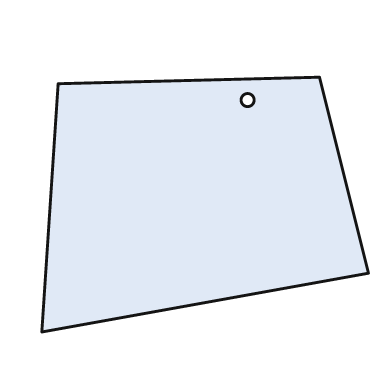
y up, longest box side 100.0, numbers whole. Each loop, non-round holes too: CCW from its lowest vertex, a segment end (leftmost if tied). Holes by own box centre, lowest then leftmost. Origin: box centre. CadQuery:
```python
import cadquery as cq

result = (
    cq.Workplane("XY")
    .moveTo(-50.0, -39.0)
    .lineTo(50.0, -21.0)
    .lineTo(35.0, 39.0)
    .lineTo(-45.0, 37.0)
    .close()
    .moveTo(13.0, 32.0)
    .circle(2.0)
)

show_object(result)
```